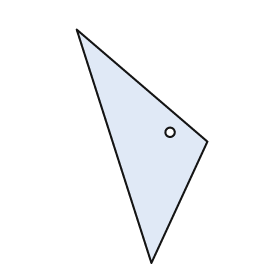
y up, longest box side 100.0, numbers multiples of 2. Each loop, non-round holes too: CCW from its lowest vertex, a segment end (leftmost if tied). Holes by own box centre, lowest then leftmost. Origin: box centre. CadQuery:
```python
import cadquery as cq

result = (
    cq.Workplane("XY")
    .moveTo(4.0, -50.0)
    .lineTo(28.0, 2.0)
    .lineTo(-28.0, 50.0)
    .close()
    .moveTo(12.0, 6.0)
    .circle(2.0)
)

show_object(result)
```